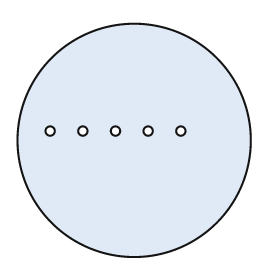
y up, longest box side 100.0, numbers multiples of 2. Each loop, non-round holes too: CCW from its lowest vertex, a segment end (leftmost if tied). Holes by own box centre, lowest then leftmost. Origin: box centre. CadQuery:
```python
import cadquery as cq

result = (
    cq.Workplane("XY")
    .moveTo(0.0, 0.0)
    .circle(50.0)
    .moveTo(-36.0, 4.0)
    .circle(2.0)
    .moveTo(-22.0, 4.0)
    .circle(2.0)
    .moveTo(-8.0, 4.0)
    .circle(2.0)
    .moveTo(6.0, 4.0)
    .circle(2.0)
    .moveTo(20.0, 4.0)
    .circle(2.0)
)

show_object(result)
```